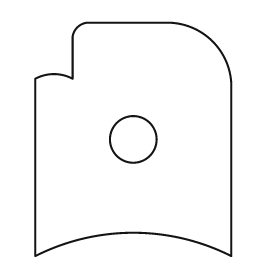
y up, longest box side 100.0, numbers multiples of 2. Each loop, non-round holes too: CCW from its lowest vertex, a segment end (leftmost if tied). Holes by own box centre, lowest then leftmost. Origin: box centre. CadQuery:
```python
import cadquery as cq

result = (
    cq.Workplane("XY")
    .moveTo(-42.0, -50.0)
    .threePointArc((0.0, -40.0), (42.0, -50.0))
    .lineTo(42.0, 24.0)
    .threePointArc((34.0, 42.0), (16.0, 50.0))
    .lineTo(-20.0, 50.0)
    .threePointArc((-24.0, 48.0), (-26.0, 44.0))
    .lineTo(-26.0, 26.0)
    .threePointArc((-34.0, 28.0), (-42.0, 26.0))
    .close()
    .moveTo(0.0, 0.0)
    .circle(10.0)
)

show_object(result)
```